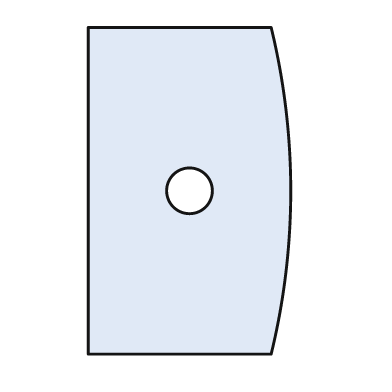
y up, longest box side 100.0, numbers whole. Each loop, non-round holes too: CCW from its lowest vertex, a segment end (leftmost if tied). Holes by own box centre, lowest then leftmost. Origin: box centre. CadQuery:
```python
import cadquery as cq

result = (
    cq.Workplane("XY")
    .moveTo(-31.0, -50.0)
    .lineTo(25.0, -50.0)
    .threePointArc((31.0, 0.0), (25.0, 50.0))
    .lineTo(-31.0, 50.0)
    .close()
    .moveTo(0.0, 0.0)
    .circle(7.0)
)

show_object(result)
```